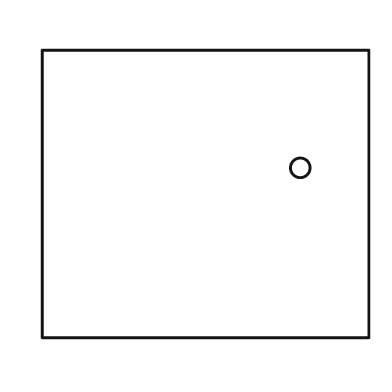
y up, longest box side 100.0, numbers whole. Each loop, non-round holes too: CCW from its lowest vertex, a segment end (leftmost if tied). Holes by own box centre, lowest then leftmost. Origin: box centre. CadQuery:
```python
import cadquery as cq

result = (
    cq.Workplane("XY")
    .moveTo(-50.0, -44.0)
    .lineTo(50.0, -44.0)
    .lineTo(50.0, 44.0)
    .lineTo(-50.0, 44.0)
    .close()
    .moveTo(29.0, 8.0)
    .circle(3.0)
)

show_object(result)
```